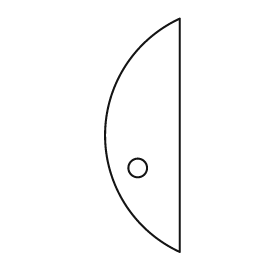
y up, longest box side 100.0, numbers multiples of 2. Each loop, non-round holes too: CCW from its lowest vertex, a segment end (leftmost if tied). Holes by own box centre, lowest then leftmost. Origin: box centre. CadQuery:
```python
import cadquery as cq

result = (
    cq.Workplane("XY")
    .moveTo(16.0, -50.0)
    .lineTo(16.0, 50.0)
    .threePointArc((-16.0, 0.0), (16.0, -50.0))
    .close()
    .moveTo(-2.0, -14.0)
    .circle(4.0)
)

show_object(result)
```